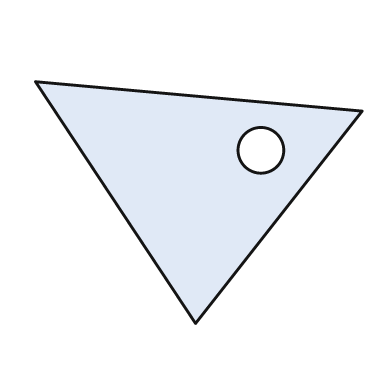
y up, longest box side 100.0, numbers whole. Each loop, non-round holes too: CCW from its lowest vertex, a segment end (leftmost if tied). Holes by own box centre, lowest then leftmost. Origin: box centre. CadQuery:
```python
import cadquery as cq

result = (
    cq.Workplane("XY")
    .moveTo(-1.0, -37.0)
    .lineTo(50.0, 28.0)
    .lineTo(-50.0, 37.0)
    .close()
    .moveTo(19.0, 16.0)
    .circle(7.0)
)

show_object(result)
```